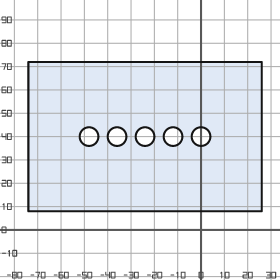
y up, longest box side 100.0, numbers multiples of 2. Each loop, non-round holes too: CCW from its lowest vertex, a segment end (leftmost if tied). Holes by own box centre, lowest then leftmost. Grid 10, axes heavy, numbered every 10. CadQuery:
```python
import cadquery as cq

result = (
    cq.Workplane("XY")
    .moveTo(-74.0, 8.0)
    .lineTo(26.0, 8.0)
    .lineTo(26.0, 72.0)
    .lineTo(-74.0, 72.0)
    .close()
    .moveTo(-48.0, 40.0)
    .circle(4.0)
    .moveTo(-36.0, 40.0)
    .circle(4.0)
    .moveTo(-24.0, 40.0)
    .circle(4.0)
    .moveTo(-12.0, 40.0)
    .circle(4.0)
    .moveTo(0.0, 40.0)
    .circle(4.0)
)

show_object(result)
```